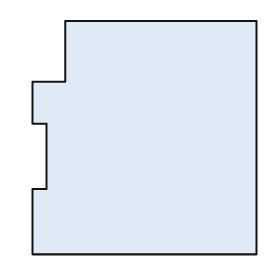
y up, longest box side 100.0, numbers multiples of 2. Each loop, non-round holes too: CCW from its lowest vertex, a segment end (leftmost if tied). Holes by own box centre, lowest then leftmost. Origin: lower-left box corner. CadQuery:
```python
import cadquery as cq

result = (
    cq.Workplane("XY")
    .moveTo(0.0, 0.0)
    .lineTo(96.0, 0.0)
    .lineTo(96.0, 100.0)
    .lineTo(14.0, 100.0)
    .lineTo(14.0, 74.0)
    .lineTo(0.0, 74.0)
    .lineTo(0.0, 56.0)
    .lineTo(6.0, 56.0)
    .lineTo(6.0, 28.0)
    .lineTo(0.0, 28.0)
    .close()
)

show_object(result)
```